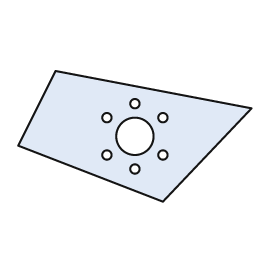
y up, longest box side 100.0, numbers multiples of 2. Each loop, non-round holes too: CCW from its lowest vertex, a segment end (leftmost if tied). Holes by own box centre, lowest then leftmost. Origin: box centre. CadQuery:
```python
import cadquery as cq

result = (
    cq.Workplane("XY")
    .moveTo(12.0, -28.0)
    .lineTo(50.0, 12.0)
    .lineTo(-34.0, 28.0)
    .lineTo(-50.0, -4.0)
    .close()
    .moveTo(0.0, -14.0)
    .circle(2.0)
    .moveTo(-12.0, -8.0)
    .circle(2.0)
    .moveTo(12.0, -8.0)
    .circle(2.0)
    .moveTo(0.0, 0.0)
    .circle(8.0)
    .moveTo(-12.0, 8.0)
    .circle(2.0)
    .moveTo(12.0, 8.0)
    .circle(2.0)
    .moveTo(0.0, 14.0)
    .circle(2.0)
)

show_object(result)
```